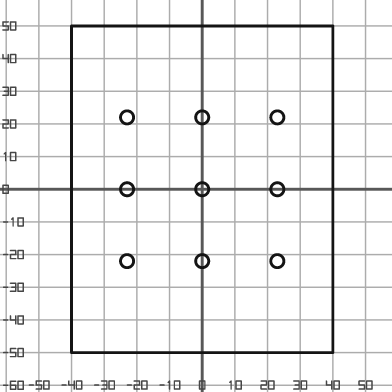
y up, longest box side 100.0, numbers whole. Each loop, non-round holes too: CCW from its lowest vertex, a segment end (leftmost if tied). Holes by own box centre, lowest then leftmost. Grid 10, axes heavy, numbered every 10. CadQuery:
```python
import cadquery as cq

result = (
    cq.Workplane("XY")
    .moveTo(-40.0, -50.0)
    .lineTo(40.0, -50.0)
    .lineTo(40.0, 50.0)
    .lineTo(-40.0, 50.0)
    .close()
    .moveTo(-23.0, -22.0)
    .circle(2.0)
    .moveTo(0.0, -22.0)
    .circle(2.0)
    .moveTo(23.0, -22.0)
    .circle(2.0)
    .moveTo(-23.0, 0.0)
    .circle(2.0)
    .moveTo(0.0, 0.0)
    .circle(2.0)
    .moveTo(23.0, 0.0)
    .circle(2.0)
    .moveTo(-23.0, 22.0)
    .circle(2.0)
    .moveTo(0.0, 22.0)
    .circle(2.0)
    .moveTo(23.0, 22.0)
    .circle(2.0)
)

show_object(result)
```